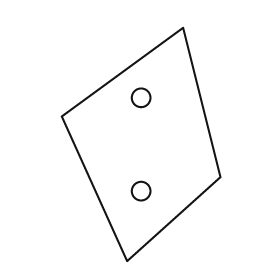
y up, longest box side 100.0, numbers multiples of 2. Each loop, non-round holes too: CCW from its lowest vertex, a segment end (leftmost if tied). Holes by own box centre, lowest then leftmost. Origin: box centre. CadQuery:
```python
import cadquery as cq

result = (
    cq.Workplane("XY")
    .moveTo(-6.0, -50.0)
    .lineTo(34.0, -14.0)
    .lineTo(18.0, 50.0)
    .lineTo(-34.0, 12.0)
    .close()
    .moveTo(0.0, -20.0)
    .circle(4.0)
    .moveTo(0.0, 20.0)
    .circle(4.0)
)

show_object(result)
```